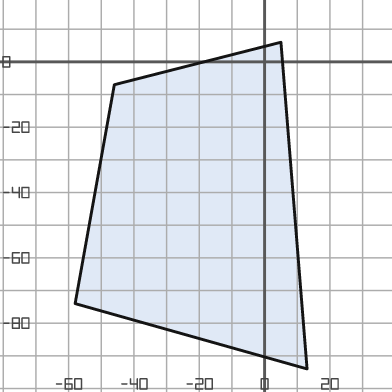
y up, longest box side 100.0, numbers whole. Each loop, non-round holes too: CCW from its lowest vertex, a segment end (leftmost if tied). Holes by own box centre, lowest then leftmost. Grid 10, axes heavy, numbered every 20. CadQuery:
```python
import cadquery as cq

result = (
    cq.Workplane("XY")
    .moveTo(13.0, -94.0)
    .lineTo(5.0, 6.0)
    .lineTo(-46.0, -7.0)
    .lineTo(-58.0, -74.0)
    .close()
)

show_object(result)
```